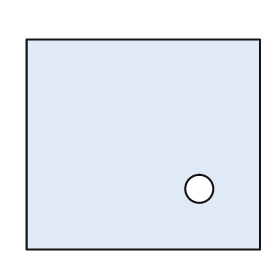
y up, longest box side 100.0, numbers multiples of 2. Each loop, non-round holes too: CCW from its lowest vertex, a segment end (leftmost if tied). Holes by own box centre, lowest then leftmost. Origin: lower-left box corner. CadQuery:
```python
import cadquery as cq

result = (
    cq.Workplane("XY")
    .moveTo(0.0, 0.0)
    .lineTo(100.0, 0.0)
    .lineTo(100.0, 90.0)
    .lineTo(0.0, 90.0)
    .close()
    .moveTo(74.0, 26.0)
    .circle(6.0)
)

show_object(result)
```